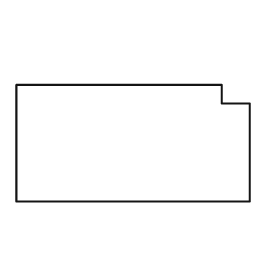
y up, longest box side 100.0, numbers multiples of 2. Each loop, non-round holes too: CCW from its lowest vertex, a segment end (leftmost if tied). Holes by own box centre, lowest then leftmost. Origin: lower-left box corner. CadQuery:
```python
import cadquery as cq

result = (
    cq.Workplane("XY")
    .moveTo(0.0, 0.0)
    .lineTo(100.0, 0.0)
    .lineTo(100.0, 42.0)
    .lineTo(88.0, 42.0)
    .lineTo(88.0, 50.0)
    .lineTo(0.0, 50.0)
    .close()
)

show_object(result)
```